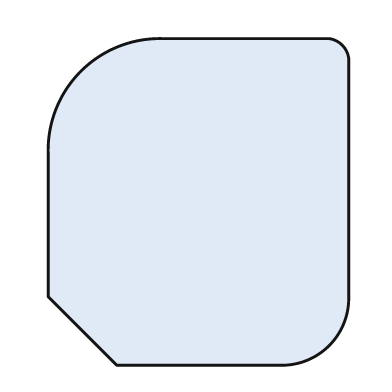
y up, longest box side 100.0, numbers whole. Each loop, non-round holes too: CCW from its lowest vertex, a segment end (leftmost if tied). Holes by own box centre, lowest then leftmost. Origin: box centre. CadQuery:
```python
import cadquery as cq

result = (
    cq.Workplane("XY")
    .moveTo(-25.0, -50.0)
    .lineTo(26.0, -50.0)
    .threePointArc((40.0, -44.0), (46.0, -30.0))
    .lineTo(46.0, 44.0)
    .threePointArc((44.0, 48.0), (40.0, 50.0))
    .lineTo(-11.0, 50.0)
    .threePointArc((-36.0, 40.0), (-46.0, 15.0))
    .lineTo(-46.0, -29.0)
    .close()
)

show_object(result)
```